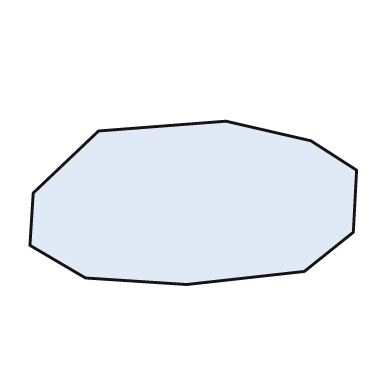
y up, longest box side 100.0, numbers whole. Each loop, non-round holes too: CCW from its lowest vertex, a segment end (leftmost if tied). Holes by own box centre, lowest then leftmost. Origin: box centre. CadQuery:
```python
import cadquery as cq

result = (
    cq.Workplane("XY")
    .moveTo(-2.0, -25.0)
    .lineTo(34.0, -21.0)
    .lineTo(49.0, -9.0)
    .lineTo(50.0, 10.0)
    .lineTo(36.0, 19.0)
    .lineTo(10.0, 25.0)
    .lineTo(-29.0, 22.0)
    .lineTo(-49.0, 3.0)
    .lineTo(-50.0, -13.0)
    .lineTo(-33.0, -23.0)
    .close()
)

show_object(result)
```